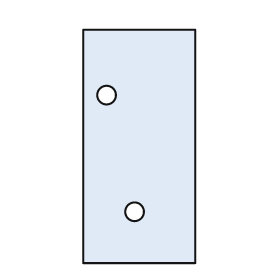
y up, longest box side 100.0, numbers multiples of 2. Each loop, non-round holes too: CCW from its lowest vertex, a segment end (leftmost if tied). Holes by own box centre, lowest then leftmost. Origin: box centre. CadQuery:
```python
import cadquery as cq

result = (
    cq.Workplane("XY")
    .moveTo(-24.0, -50.0)
    .lineTo(24.0, -50.0)
    .lineTo(24.0, 50.0)
    .lineTo(-24.0, 50.0)
    .close()
    .moveTo(-2.0, -28.0)
    .circle(4.0)
    .moveTo(-14.0, 22.0)
    .circle(4.0)
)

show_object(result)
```